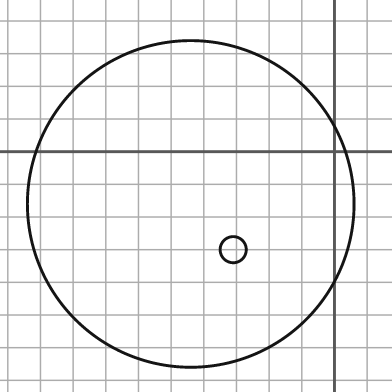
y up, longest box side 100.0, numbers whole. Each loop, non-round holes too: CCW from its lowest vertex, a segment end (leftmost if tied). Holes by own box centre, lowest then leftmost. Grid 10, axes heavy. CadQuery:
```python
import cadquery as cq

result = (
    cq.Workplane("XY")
    .moveTo(-44.0, -16.0)
    .circle(50.0)
    .moveTo(-31.0, -30.0)
    .circle(4.0)
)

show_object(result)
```